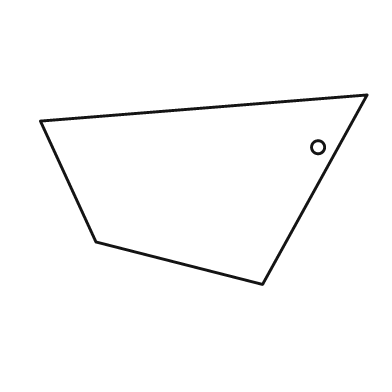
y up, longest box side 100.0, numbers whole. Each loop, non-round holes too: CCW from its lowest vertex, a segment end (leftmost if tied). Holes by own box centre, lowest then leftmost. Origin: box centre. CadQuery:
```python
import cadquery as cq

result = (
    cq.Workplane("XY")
    .moveTo(18.0, -29.0)
    .lineTo(50.0, 29.0)
    .lineTo(-50.0, 21.0)
    .lineTo(-33.0, -16.0)
    .close()
    .moveTo(35.0, 13.0)
    .circle(2.0)
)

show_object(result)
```